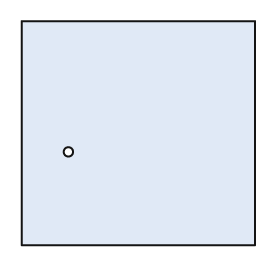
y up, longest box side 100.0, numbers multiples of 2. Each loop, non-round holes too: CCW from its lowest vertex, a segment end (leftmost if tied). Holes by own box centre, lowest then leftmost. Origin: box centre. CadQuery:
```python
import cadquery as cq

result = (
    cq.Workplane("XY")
    .moveTo(-50.0, -48.0)
    .lineTo(50.0, -48.0)
    .lineTo(50.0, 48.0)
    .lineTo(-50.0, 48.0)
    .close()
    .moveTo(-30.0, -8.0)
    .circle(2.0)
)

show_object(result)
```